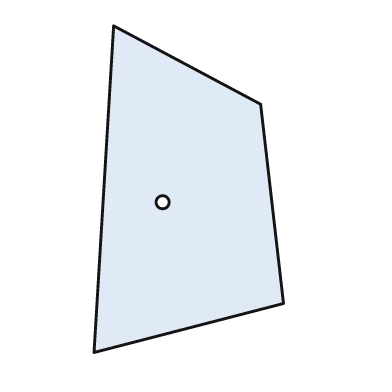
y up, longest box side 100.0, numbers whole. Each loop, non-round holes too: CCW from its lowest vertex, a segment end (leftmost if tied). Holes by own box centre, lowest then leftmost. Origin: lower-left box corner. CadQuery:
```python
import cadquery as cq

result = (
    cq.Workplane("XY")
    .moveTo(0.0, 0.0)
    .lineTo(58.0, 15.0)
    .lineTo(51.0, 76.0)
    .lineTo(6.0, 100.0)
    .close()
    .moveTo(21.0, 46.0)
    .circle(2.0)
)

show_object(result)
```